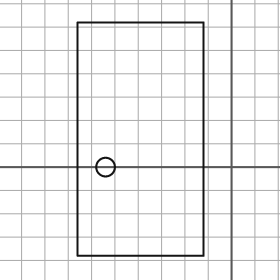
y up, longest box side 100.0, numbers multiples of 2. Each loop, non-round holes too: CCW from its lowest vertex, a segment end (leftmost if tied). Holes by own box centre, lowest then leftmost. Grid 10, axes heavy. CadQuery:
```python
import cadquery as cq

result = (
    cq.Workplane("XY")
    .moveTo(-66.0, -38.0)
    .lineTo(-12.0, -38.0)
    .lineTo(-12.0, 62.0)
    .lineTo(-66.0, 62.0)
    .close()
    .moveTo(-54.0, 0.0)
    .circle(4.0)
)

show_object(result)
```